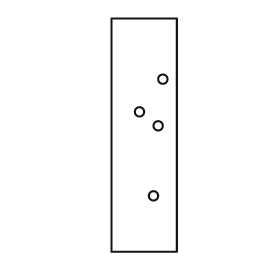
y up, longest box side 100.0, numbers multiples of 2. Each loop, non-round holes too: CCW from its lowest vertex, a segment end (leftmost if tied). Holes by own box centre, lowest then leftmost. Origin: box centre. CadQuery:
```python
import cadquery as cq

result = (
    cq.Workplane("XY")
    .moveTo(-14.0, -50.0)
    .lineTo(14.0, -50.0)
    .lineTo(14.0, 50.0)
    .lineTo(-14.0, 50.0)
    .close()
    .moveTo(4.0, -26.0)
    .circle(2.0)
    .moveTo(6.0, 4.0)
    .circle(2.0)
    .moveTo(-2.0, 10.0)
    .circle(2.0)
    .moveTo(8.0, 24.0)
    .circle(2.0)
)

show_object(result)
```